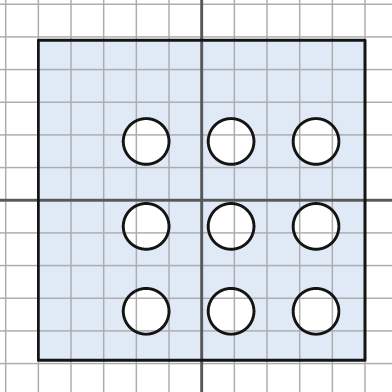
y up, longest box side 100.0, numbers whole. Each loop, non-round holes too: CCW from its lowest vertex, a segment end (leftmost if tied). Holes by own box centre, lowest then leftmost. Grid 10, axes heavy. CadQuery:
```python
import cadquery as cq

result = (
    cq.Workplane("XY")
    .moveTo(-50.0, -49.0)
    .lineTo(50.0, -49.0)
    .lineTo(50.0, 49.0)
    .lineTo(-50.0, 49.0)
    .close()
    .moveTo(-17.0, -34.0)
    .circle(7.0)
    .moveTo(9.0, -34.0)
    .circle(7.0)
    .moveTo(35.0, -34.0)
    .circle(7.0)
    .moveTo(-17.0, -8.0)
    .circle(7.0)
    .moveTo(9.0, -8.0)
    .circle(7.0)
    .moveTo(35.0, -8.0)
    .circle(7.0)
    .moveTo(-17.0, 18.0)
    .circle(7.0)
    .moveTo(9.0, 18.0)
    .circle(7.0)
    .moveTo(35.0, 18.0)
    .circle(7.0)
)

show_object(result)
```